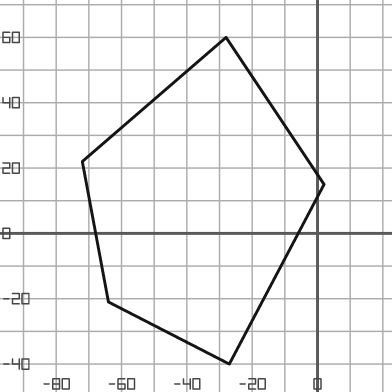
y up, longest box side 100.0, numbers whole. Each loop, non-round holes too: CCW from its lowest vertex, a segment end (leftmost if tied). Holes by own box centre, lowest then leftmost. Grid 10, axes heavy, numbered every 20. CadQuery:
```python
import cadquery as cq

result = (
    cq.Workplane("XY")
    .moveTo(-27.0, -40.0)
    .lineTo(2.0, 15.0)
    .lineTo(-28.0, 60.0)
    .lineTo(-72.0, 22.0)
    .lineTo(-64.0, -21.0)
    .close()
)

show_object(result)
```